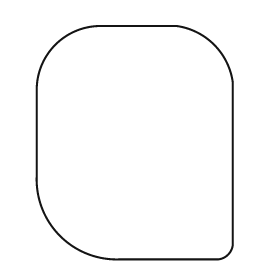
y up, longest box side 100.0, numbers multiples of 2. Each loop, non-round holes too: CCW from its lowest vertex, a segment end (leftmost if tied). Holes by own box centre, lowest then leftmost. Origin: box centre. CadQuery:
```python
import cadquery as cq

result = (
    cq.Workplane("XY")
    .moveTo(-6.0, -50.0)
    .lineTo(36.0, -50.0)
    .threePointArc((40.0, -48.0), (42.0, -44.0))
    .lineTo(42.0, 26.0)
    .threePointArc((34.0, 42.0), (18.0, 50.0))
    .lineTo(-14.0, 50.0)
    .threePointArc((-34.0, 42.0), (-42.0, 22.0))
    .lineTo(-42.0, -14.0)
    .threePointArc((-32.0, -40.0), (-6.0, -50.0))
    .close()
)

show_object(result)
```